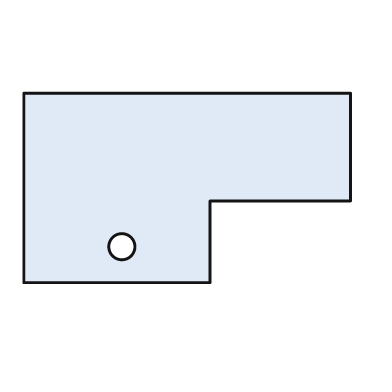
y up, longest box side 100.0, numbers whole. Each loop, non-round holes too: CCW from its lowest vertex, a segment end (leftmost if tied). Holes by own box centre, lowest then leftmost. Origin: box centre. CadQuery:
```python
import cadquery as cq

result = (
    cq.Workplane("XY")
    .moveTo(-50.0, -29.0)
    .lineTo(7.0, -29.0)
    .lineTo(7.0, -4.0)
    .lineTo(50.0, -4.0)
    .lineTo(50.0, 29.0)
    .lineTo(-50.0, 29.0)
    .close()
    .moveTo(-20.0, -18.0)
    .circle(4.0)
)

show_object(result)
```